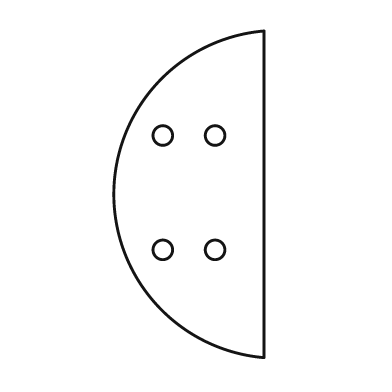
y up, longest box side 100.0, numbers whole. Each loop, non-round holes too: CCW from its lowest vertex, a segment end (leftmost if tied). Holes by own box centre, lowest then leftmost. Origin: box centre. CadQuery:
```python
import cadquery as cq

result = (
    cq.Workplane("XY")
    .moveTo(23.0, -50.0)
    .lineTo(23.0, 50.0)
    .threePointArc((-23.0, 0.0), (23.0, -50.0))
    .close()
    .moveTo(-8.0, -17.0)
    .circle(3.0)
    .moveTo(8.0, -17.0)
    .circle(3.0)
    .moveTo(-8.0, 18.0)
    .circle(3.0)
    .moveTo(8.0, 18.0)
    .circle(3.0)
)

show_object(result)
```